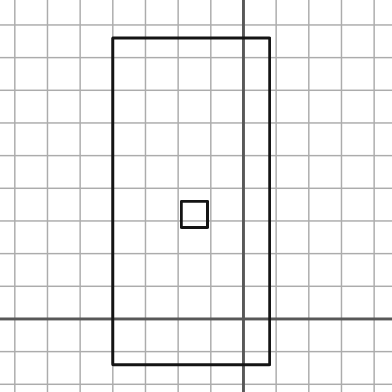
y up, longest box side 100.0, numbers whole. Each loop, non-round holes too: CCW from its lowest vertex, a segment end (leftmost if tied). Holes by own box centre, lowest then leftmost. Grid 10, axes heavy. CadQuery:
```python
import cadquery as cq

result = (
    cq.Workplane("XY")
    .moveTo(-40.0, -14.0)
    .lineTo(8.0, -14.0)
    .lineTo(8.0, 86.0)
    .lineTo(-40.0, 86.0)
    .close()
    .moveTo(-19.0, 28.0)
    .lineTo(-11.0, 28.0)
    .lineTo(-11.0, 36.0)
    .lineTo(-19.0, 36.0)
    .close()
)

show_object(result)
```